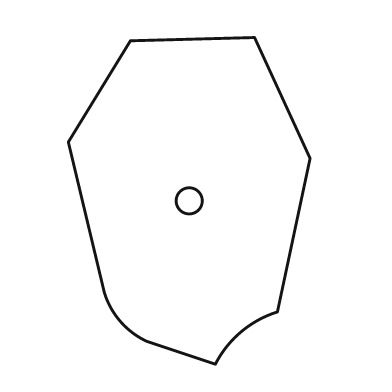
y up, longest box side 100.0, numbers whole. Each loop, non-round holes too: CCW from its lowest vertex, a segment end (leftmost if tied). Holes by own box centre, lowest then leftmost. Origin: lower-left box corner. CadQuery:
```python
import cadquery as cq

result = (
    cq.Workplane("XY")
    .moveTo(45.0, 0.0)
    .threePointArc((53.0, 10.0), (64.0, 16.0))
    .lineTo(74.0, 63.0)
    .lineTo(57.0, 100.0)
    .lineTo(19.0, 99.0)
    .lineTo(0.0, 68.0)
    .lineTo(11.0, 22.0)
    .threePointArc((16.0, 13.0), (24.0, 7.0))
    .close()
    .moveTo(37.0, 50.0)
    .circle(4.0)
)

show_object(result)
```